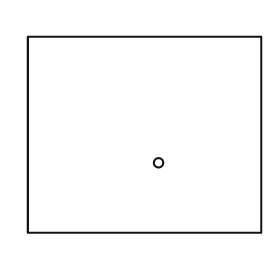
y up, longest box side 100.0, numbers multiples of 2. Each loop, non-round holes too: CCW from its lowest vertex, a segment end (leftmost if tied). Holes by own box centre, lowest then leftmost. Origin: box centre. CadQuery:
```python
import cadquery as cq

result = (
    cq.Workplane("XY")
    .moveTo(-50.0, -42.0)
    .lineTo(50.0, -42.0)
    .lineTo(50.0, 42.0)
    .lineTo(-50.0, 42.0)
    .close()
    .moveTo(6.0, -12.0)
    .circle(2.0)
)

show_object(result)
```